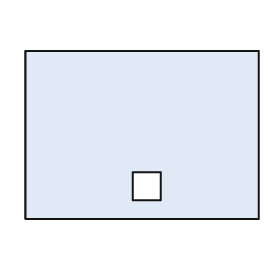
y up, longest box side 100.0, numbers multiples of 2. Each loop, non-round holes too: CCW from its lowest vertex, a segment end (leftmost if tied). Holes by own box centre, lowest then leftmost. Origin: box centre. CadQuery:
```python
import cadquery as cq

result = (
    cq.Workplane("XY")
    .moveTo(-50.0, -36.0)
    .lineTo(50.0, -36.0)
    .lineTo(50.0, 36.0)
    .lineTo(-50.0, 36.0)
    .close()
    .moveTo(-4.0, -28.0)
    .lineTo(8.0, -28.0)
    .lineTo(8.0, -16.0)
    .lineTo(-4.0, -16.0)
    .close()
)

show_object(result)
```